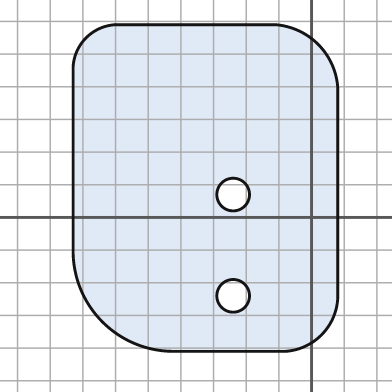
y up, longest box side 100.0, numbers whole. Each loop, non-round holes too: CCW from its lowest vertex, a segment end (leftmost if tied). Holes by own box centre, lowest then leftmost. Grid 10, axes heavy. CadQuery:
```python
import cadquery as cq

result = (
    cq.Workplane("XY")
    .moveTo(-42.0, -41.0)
    .lineTo(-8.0, -41.0)
    .threePointArc((3.0, -36.0), (8.0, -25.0))
    .lineTo(8.0, 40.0)
    .threePointArc((2.0, 53.0), (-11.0, 59.0))
    .lineTo(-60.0, 59.0)
    .threePointArc((-69.0, 55.0), (-73.0, 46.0))
    .lineTo(-73.0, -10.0)
    .threePointArc((-64.0, -32.0), (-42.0, -41.0))
    .close()
    .moveTo(-24.0, -24.0)
    .circle(5.0)
    .moveTo(-24.0, 7.0)
    .circle(5.0)
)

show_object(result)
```